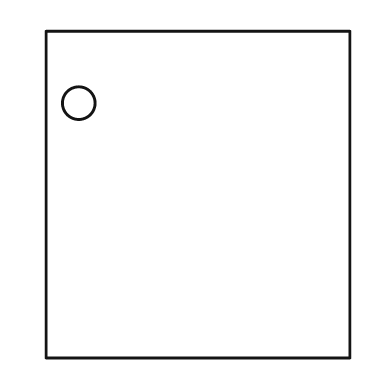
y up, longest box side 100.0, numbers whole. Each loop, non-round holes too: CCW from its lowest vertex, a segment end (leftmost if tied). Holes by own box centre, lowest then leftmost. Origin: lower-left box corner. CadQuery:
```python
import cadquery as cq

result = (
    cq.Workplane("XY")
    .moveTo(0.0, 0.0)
    .lineTo(93.0, 0.0)
    .lineTo(93.0, 100.0)
    .lineTo(0.0, 100.0)
    .close()
    .moveTo(10.0, 78.0)
    .circle(5.0)
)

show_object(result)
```